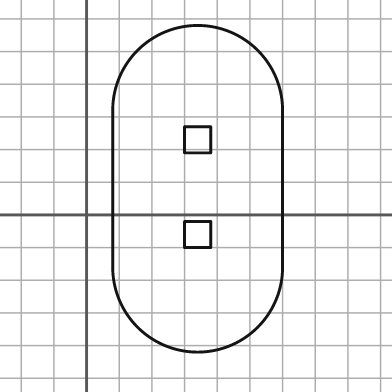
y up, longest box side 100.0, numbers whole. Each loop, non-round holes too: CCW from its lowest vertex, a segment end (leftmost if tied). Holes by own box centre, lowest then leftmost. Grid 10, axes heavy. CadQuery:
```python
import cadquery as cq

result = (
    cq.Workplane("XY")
    .moveTo(8.0, -16.0)
    .threePointArc((34.0, -42.0), (60.0, -16.0))
    .lineTo(60.0, 32.0)
    .threePointArc((34.0, 58.0), (8.0, 32.0))
    .close()
    .moveTo(30.0, -10.0)
    .lineTo(38.0, -10.0)
    .lineTo(38.0, -2.0)
    .lineTo(30.0, -2.0)
    .close()
    .moveTo(30.0, 19.0)
    .lineTo(38.0, 19.0)
    .lineTo(38.0, 27.0)
    .lineTo(30.0, 27.0)
    .close()
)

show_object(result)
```